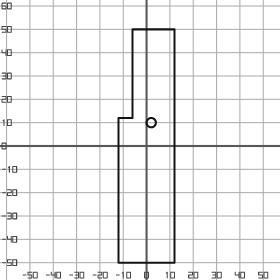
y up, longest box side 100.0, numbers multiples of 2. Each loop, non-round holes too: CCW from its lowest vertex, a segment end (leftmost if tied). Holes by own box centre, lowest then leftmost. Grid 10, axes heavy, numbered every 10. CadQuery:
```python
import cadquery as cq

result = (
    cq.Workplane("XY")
    .moveTo(-12.0, -50.0)
    .lineTo(12.0, -50.0)
    .lineTo(12.0, 50.0)
    .lineTo(-6.0, 50.0)
    .lineTo(-6.0, 12.0)
    .lineTo(-12.0, 12.0)
    .close()
    .moveTo(2.0, 10.0)
    .circle(2.0)
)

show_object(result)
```